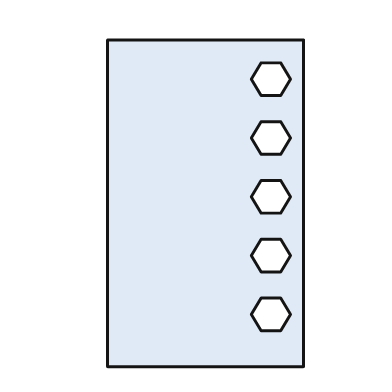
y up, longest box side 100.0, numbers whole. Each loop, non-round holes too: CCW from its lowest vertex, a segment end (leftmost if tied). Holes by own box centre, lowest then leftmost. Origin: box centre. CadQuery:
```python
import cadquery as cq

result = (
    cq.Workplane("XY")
    .moveTo(-30.0, -50.0)
    .lineTo(30.0, -50.0)
    .lineTo(30.0, 50.0)
    .lineTo(-30.0, 50.0)
    .close()
    .moveTo(17.0, -39.0)
    .lineTo(23.0, -39.0)
    .lineTo(26.0, -34.0)
    .lineTo(23.0, -29.0)
    .lineTo(17.0, -29.0)
    .lineTo(14.0, -34.0)
    .close()
    .moveTo(17.0, -21.0)
    .lineTo(23.0, -21.0)
    .lineTo(26.0, -16.0)
    .lineTo(23.0, -11.0)
    .lineTo(17.0, -11.0)
    .lineTo(14.0, -16.0)
    .close()
    .moveTo(17.0, -3.0)
    .lineTo(23.0, -3.0)
    .lineTo(26.0, 2.0)
    .lineTo(23.0, 7.0)
    .lineTo(17.0, 7.0)
    .lineTo(14.0, 2.0)
    .close()
    .moveTo(17.0, 15.0)
    .lineTo(23.0, 15.0)
    .lineTo(26.0, 20.0)
    .lineTo(23.0, 25.0)
    .lineTo(17.0, 25.0)
    .lineTo(14.0, 20.0)
    .close()
    .moveTo(17.0, 33.0)
    .lineTo(23.0, 33.0)
    .lineTo(26.0, 38.0)
    .lineTo(23.0, 43.0)
    .lineTo(17.0, 43.0)
    .lineTo(14.0, 38.0)
    .close()
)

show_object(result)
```